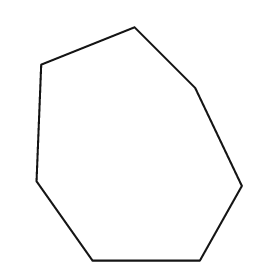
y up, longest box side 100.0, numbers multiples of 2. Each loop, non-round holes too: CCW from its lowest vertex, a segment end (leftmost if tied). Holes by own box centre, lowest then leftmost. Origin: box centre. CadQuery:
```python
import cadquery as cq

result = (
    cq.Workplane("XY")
    .moveTo(-20.0, -50.0)
    .lineTo(26.0, -50.0)
    .lineTo(44.0, -18.0)
    .lineTo(24.0, 24.0)
    .lineTo(-2.0, 50.0)
    .lineTo(-42.0, 34.0)
    .lineTo(-44.0, -16.0)
    .close()
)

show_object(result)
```